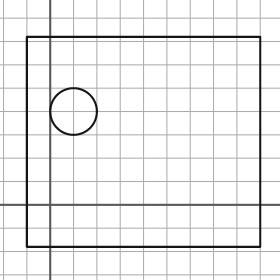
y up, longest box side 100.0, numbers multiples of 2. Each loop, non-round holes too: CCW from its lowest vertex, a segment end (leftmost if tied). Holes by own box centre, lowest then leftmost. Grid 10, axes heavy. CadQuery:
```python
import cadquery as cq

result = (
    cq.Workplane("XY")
    .moveTo(-10.0, -18.0)
    .lineTo(90.0, -18.0)
    .lineTo(90.0, 72.0)
    .lineTo(-10.0, 72.0)
    .close()
    .moveTo(10.0, 40.0)
    .circle(10.0)
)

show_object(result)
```